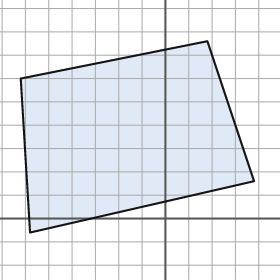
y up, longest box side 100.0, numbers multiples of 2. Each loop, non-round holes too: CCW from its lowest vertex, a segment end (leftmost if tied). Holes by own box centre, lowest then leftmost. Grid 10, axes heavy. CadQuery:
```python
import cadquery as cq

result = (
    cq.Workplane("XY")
    .moveTo(-58.0, -6.0)
    .lineTo(38.0, 16.0)
    .lineTo(18.0, 76.0)
    .lineTo(-62.0, 60.0)
    .close()
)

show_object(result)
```